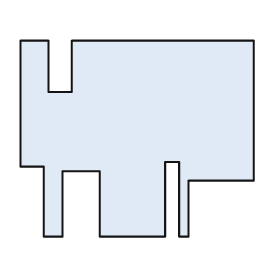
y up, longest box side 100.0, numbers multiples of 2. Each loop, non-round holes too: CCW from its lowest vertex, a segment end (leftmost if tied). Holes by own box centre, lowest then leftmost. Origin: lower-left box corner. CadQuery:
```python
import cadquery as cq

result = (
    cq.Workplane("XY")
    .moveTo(10.0, 0.0)
    .lineTo(18.0, 0.0)
    .lineTo(18.0, 28.0)
    .lineTo(34.0, 28.0)
    .lineTo(34.0, 0.0)
    .lineTo(62.0, 0.0)
    .lineTo(62.0, 32.0)
    .lineTo(68.0, 32.0)
    .lineTo(68.0, 0.0)
    .lineTo(72.0, 0.0)
    .lineTo(72.0, 24.0)
    .lineTo(100.0, 24.0)
    .lineTo(100.0, 84.0)
    .lineTo(22.0, 84.0)
    .lineTo(22.0, 62.0)
    .lineTo(12.0, 62.0)
    .lineTo(12.0, 84.0)
    .lineTo(0.0, 84.0)
    .lineTo(0.0, 30.0)
    .lineTo(10.0, 30.0)
    .close()
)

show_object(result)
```